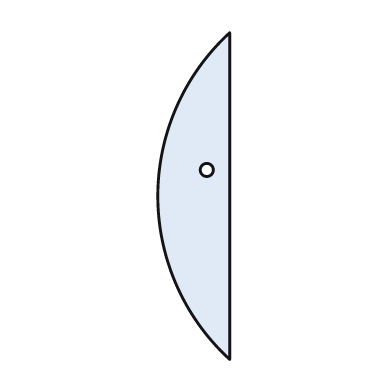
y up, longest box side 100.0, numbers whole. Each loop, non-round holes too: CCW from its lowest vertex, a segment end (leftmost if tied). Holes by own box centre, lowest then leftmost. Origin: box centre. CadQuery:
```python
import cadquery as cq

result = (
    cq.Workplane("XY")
    .moveTo(11.0, -50.0)
    .lineTo(11.0, 50.0)
    .threePointArc((-11.0, 0.0), (11.0, -50.0))
    .close()
    .moveTo(4.0, 8.0)
    .circle(2.0)
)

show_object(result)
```